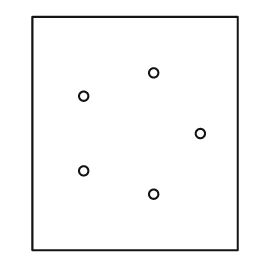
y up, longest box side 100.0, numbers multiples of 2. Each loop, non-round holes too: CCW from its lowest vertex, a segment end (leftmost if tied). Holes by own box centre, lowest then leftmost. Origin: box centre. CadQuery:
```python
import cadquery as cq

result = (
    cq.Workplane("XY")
    .moveTo(-44.0, -50.0)
    .lineTo(44.0, -50.0)
    .lineTo(44.0, 50.0)
    .lineTo(-44.0, 50.0)
    .close()
    .moveTo(8.0, -26.0)
    .circle(2.0)
    .moveTo(-22.0, -16.0)
    .circle(2.0)
    .moveTo(28.0, 0.0)
    .circle(2.0)
    .moveTo(-22.0, 16.0)
    .circle(2.0)
    .moveTo(8.0, 26.0)
    .circle(2.0)
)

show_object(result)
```